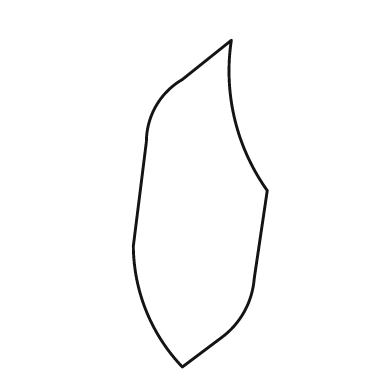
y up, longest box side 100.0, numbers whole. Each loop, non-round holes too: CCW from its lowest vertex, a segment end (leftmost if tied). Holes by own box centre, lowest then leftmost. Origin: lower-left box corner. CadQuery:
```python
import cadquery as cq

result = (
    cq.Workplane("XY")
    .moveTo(15.0, 0.0)
    .lineTo(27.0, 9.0)
    .threePointArc((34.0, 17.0), (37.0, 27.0))
    .lineTo(41.0, 54.0)
    .threePointArc((31.0, 76.0), (30.0, 100.0))
    .lineTo(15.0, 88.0)
    .threePointArc((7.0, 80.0), (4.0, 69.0))
    .lineTo(0.0, 37.0)
    .threePointArc((4.0, 17.0), (15.0, 0.0))
    .close()
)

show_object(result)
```